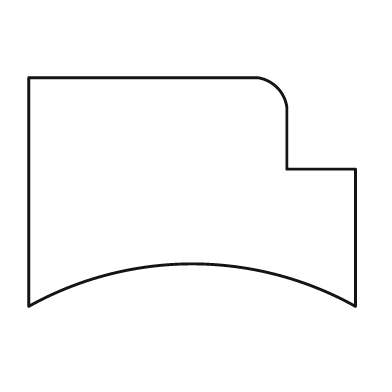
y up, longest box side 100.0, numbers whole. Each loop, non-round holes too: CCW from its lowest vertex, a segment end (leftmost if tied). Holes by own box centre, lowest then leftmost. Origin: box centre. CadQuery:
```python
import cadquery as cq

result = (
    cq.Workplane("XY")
    .moveTo(-50.0, -35.0)
    .threePointArc((0.0, -22.0), (50.0, -35.0))
    .lineTo(50.0, 7.0)
    .lineTo(29.0, 7.0)
    .lineTo(29.0, 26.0)
    .threePointArc((26.0, 32.0), (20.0, 35.0))
    .lineTo(-50.0, 35.0)
    .close()
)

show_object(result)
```